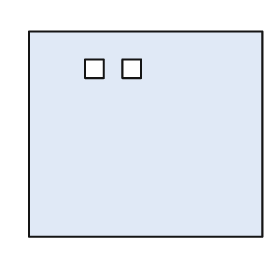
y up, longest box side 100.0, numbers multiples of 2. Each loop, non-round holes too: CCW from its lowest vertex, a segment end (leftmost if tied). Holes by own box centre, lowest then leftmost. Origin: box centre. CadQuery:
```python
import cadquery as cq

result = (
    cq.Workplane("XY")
    .moveTo(-50.0, -44.0)
    .lineTo(50.0, -44.0)
    .lineTo(50.0, 44.0)
    .lineTo(-50.0, 44.0)
    .close()
    .moveTo(-26.0, 24.0)
    .lineTo(-18.0, 24.0)
    .lineTo(-18.0, 32.0)
    .lineTo(-26.0, 32.0)
    .close()
    .moveTo(-10.0, 24.0)
    .lineTo(-2.0, 24.0)
    .lineTo(-2.0, 32.0)
    .lineTo(-10.0, 32.0)
    .close()
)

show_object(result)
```